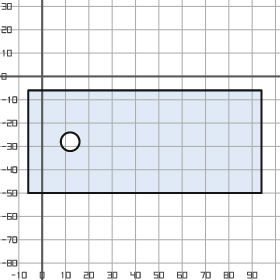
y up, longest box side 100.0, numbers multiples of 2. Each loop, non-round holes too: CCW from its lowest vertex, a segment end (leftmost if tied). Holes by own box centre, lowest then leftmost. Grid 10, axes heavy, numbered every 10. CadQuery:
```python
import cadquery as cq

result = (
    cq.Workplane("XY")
    .moveTo(-6.0, -50.0)
    .lineTo(94.0, -50.0)
    .lineTo(94.0, -6.0)
    .lineTo(-6.0, -6.0)
    .close()
    .moveTo(12.0, -28.0)
    .circle(4.0)
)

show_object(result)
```